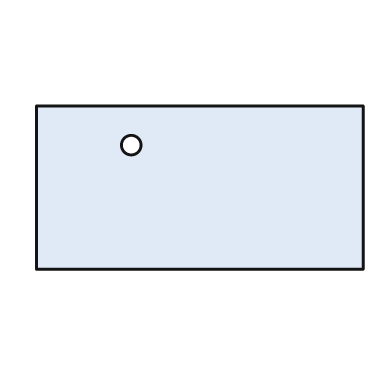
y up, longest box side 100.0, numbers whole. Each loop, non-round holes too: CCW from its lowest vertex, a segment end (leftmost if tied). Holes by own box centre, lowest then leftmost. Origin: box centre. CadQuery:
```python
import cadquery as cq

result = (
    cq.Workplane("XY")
    .moveTo(-50.0, -25.0)
    .lineTo(50.0, -25.0)
    .lineTo(50.0, 25.0)
    .lineTo(-50.0, 25.0)
    .close()
    .moveTo(-21.0, 13.0)
    .circle(3.0)
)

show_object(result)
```